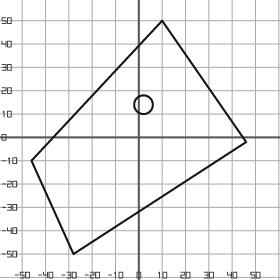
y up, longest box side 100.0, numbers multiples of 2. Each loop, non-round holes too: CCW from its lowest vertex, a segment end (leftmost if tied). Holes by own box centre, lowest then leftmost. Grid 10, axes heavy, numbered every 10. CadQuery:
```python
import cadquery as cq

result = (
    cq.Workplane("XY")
    .moveTo(-28.0, -50.0)
    .lineTo(46.0, -2.0)
    .lineTo(10.0, 50.0)
    .lineTo(-46.0, -10.0)
    .close()
    .moveTo(2.0, 14.0)
    .circle(4.0)
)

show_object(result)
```